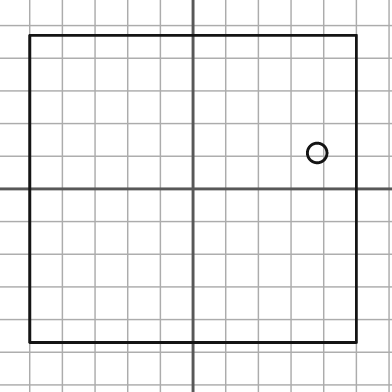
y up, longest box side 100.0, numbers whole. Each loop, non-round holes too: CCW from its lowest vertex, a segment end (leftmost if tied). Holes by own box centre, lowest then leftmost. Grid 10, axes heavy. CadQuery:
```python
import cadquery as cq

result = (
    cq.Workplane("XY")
    .moveTo(-50.0, -47.0)
    .lineTo(50.0, -47.0)
    .lineTo(50.0, 47.0)
    .lineTo(-50.0, 47.0)
    .close()
    .moveTo(38.0, 11.0)
    .circle(3.0)
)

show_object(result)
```